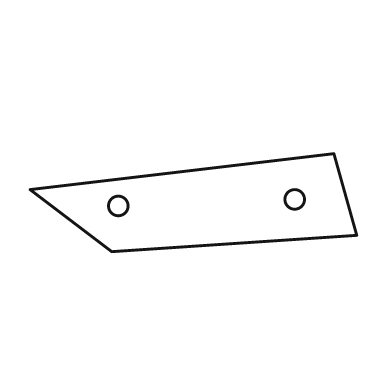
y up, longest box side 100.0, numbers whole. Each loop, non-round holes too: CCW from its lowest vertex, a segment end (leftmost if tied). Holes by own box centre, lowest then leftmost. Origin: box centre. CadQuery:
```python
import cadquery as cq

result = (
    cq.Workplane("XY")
    .moveTo(-25.0, -15.0)
    .lineTo(50.0, -10.0)
    .lineTo(43.0, 15.0)
    .lineTo(-50.0, 4.0)
    .close()
    .moveTo(-23.0, -1.0)
    .circle(3.0)
    .moveTo(31.0, 1.0)
    .circle(3.0)
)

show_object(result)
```